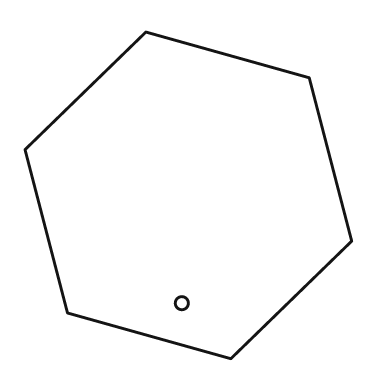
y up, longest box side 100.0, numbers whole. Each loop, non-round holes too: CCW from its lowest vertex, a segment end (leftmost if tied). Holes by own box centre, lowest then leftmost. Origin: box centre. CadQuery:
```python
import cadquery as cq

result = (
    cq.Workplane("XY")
    .moveTo(13.0, -50.0)
    .lineTo(50.0, -14.0)
    .lineTo(37.0, 36.0)
    .lineTo(-13.0, 50.0)
    .lineTo(-50.0, 14.0)
    .lineTo(-37.0, -36.0)
    .close()
    .moveTo(-2.0, -33.0)
    .circle(2.0)
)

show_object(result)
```